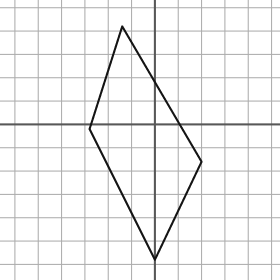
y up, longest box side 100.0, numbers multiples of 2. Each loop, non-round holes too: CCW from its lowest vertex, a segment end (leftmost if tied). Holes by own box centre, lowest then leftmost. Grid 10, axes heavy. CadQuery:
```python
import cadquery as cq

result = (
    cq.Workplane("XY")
    .moveTo(0.0, -58.0)
    .lineTo(20.0, -16.0)
    .lineTo(-14.0, 42.0)
    .lineTo(-28.0, -2.0)
    .close()
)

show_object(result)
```